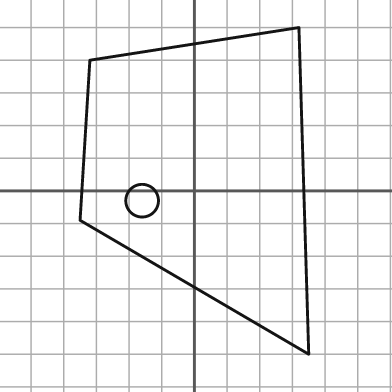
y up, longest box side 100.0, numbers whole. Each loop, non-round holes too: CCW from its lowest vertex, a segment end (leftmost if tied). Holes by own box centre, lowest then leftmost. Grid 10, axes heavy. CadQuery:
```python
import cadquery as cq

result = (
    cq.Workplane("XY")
    .moveTo(35.0, -50.0)
    .lineTo(32.0, 50.0)
    .lineTo(-32.0, 40.0)
    .lineTo(-35.0, -9.0)
    .close()
    .moveTo(-16.0, -3.0)
    .circle(5.0)
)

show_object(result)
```